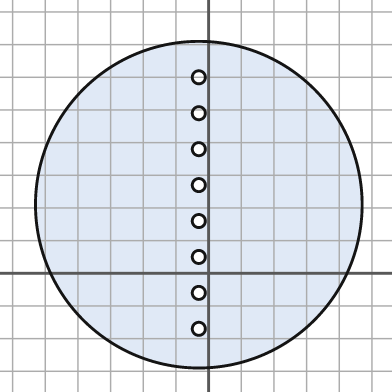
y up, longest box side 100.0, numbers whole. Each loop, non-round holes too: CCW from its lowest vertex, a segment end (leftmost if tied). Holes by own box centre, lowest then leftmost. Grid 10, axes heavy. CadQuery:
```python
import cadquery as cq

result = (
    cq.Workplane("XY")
    .moveTo(-3.0, 21.0)
    .circle(50.0)
    .moveTo(-3.0, -17.0)
    .circle(2.0)
    .moveTo(-3.0, -6.0)
    .circle(2.0)
    .moveTo(-3.0, 5.0)
    .circle(2.0)
    .moveTo(-3.0, 16.0)
    .circle(2.0)
    .moveTo(-3.0, 27.0)
    .circle(2.0)
    .moveTo(-3.0, 38.0)
    .circle(2.0)
    .moveTo(-3.0, 49.0)
    .circle(2.0)
    .moveTo(-3.0, 60.0)
    .circle(2.0)
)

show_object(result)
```